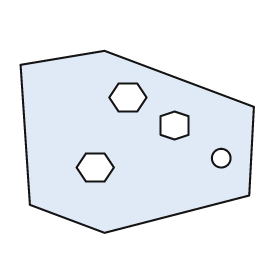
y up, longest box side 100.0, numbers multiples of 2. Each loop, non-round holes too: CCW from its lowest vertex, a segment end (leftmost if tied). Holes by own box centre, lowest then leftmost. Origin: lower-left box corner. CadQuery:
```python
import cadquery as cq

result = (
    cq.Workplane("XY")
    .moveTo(36.0, 0.0)
    .lineTo(98.0, 16.0)
    .lineTo(100.0, 54.0)
    .lineTo(36.0, 78.0)
    .lineTo(0.0, 72.0)
    .lineTo(4.0, 12.0)
    .close()
    .moveTo(28.0, 22.0)
    .lineTo(36.0, 22.0)
    .lineTo(40.0, 28.0)
    .lineTo(36.0, 34.0)
    .lineTo(28.0, 34.0)
    .lineTo(24.0, 28.0)
    .close()
    .moveTo(86.0, 32.0)
    .circle(4.0)
    .moveTo(66.0, 40.0)
    .lineTo(72.0, 42.0)
    .lineTo(72.0, 50.0)
    .lineTo(66.0, 52.0)
    .lineTo(60.0, 50.0)
    .lineTo(60.0, 42.0)
    .close()
    .moveTo(42.0, 52.0)
    .lineTo(50.0, 52.0)
    .lineTo(54.0, 58.0)
    .lineTo(50.0, 64.0)
    .lineTo(42.0, 64.0)
    .lineTo(38.0, 58.0)
    .close()
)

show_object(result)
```